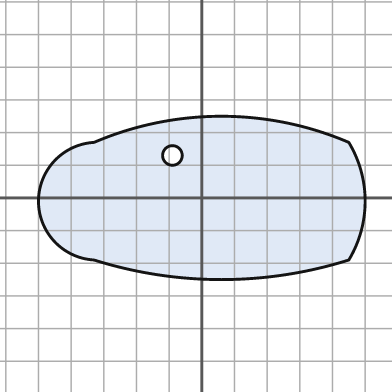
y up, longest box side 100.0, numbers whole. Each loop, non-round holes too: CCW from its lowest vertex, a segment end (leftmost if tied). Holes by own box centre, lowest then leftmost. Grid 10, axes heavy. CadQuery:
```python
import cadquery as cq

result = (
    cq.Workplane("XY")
    .moveTo(-33.0, -19.0)
    .threePointArc((6.0, -25.0), (45.0, -19.0))
    .threePointArc((50.0, -1.0), (45.0, 17.0))
    .threePointArc((6.0, 25.0), (-33.0, 17.0))
    .threePointArc((-50.0, -1.0), (-33.0, -19.0))
    .close()
    .moveTo(-9.0, 13.0)
    .circle(3.0)
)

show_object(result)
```